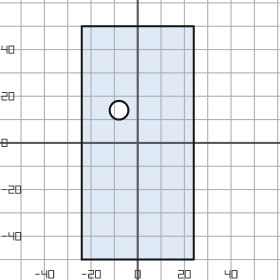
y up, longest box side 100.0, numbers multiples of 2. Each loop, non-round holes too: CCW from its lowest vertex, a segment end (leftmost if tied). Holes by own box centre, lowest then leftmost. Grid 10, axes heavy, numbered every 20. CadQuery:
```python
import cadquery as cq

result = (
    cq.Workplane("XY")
    .moveTo(-24.0, -50.0)
    .lineTo(24.0, -50.0)
    .lineTo(24.0, 50.0)
    .lineTo(-24.0, 50.0)
    .close()
    .moveTo(-8.0, 14.0)
    .circle(4.0)
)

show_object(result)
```